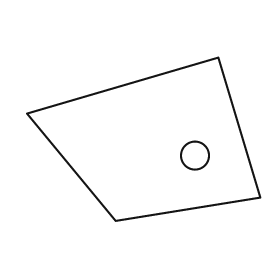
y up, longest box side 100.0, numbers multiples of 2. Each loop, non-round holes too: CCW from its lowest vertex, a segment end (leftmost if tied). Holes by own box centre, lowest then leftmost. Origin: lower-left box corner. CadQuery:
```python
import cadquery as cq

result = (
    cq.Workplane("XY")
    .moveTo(38.0, 0.0)
    .lineTo(100.0, 10.0)
    .lineTo(82.0, 70.0)
    .lineTo(0.0, 46.0)
    .close()
    .moveTo(72.0, 28.0)
    .circle(6.0)
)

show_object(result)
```